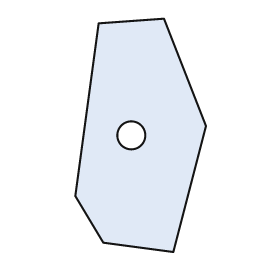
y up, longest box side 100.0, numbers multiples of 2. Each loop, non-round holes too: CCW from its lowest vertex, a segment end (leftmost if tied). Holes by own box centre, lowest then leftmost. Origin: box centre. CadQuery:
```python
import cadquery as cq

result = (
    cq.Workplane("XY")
    .moveTo(14.0, -50.0)
    .lineTo(28.0, 4.0)
    .lineTo(10.0, 50.0)
    .lineTo(-18.0, 48.0)
    .lineTo(-28.0, -26.0)
    .lineTo(-16.0, -46.0)
    .close()
    .moveTo(-4.0, 0.0)
    .circle(6.0)
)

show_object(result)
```